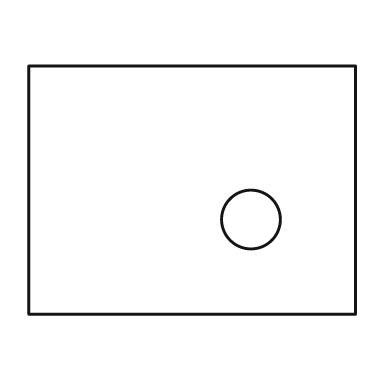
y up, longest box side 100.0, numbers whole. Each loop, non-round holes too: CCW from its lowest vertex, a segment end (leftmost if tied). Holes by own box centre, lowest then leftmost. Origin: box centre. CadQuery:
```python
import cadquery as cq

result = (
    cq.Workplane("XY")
    .moveTo(-50.0, -38.0)
    .lineTo(50.0, -38.0)
    .lineTo(50.0, 38.0)
    .lineTo(-50.0, 38.0)
    .close()
    .moveTo(18.0, -9.0)
    .circle(9.0)
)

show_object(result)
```